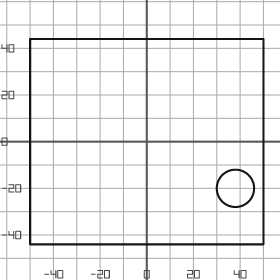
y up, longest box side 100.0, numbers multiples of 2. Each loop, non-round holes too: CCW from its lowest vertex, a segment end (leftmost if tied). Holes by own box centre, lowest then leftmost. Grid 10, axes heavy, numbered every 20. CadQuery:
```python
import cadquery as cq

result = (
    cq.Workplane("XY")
    .moveTo(-50.0, -44.0)
    .lineTo(50.0, -44.0)
    .lineTo(50.0, 44.0)
    .lineTo(-50.0, 44.0)
    .close()
    .moveTo(38.0, -20.0)
    .circle(8.0)
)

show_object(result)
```